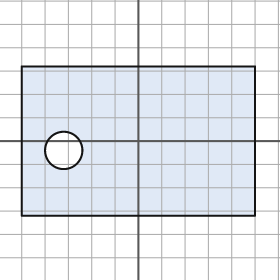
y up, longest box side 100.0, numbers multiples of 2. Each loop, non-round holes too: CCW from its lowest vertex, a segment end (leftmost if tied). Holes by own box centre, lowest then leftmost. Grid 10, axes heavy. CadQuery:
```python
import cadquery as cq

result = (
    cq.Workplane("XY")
    .moveTo(-50.0, -32.0)
    .lineTo(50.0, -32.0)
    .lineTo(50.0, 32.0)
    .lineTo(-50.0, 32.0)
    .close()
    .moveTo(-32.0, -4.0)
    .circle(8.0)
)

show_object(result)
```